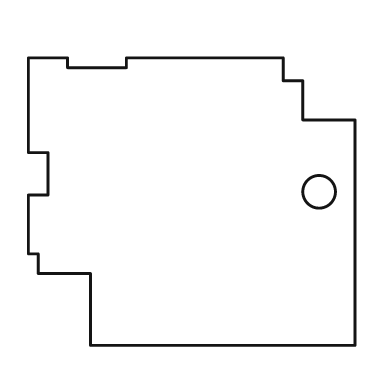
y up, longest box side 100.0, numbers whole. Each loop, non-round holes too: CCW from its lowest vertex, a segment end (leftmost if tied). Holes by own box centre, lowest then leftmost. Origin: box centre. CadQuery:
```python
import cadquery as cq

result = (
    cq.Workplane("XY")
    .moveTo(-31.0, -44.0)
    .lineTo(50.0, -44.0)
    .lineTo(50.0, 25.0)
    .lineTo(34.0, 25.0)
    .lineTo(34.0, 37.0)
    .lineTo(28.0, 37.0)
    .lineTo(28.0, 44.0)
    .lineTo(-20.0, 44.0)
    .lineTo(-20.0, 41.0)
    .lineTo(-38.0, 41.0)
    .lineTo(-38.0, 44.0)
    .lineTo(-50.0, 44.0)
    .lineTo(-50.0, 15.0)
    .lineTo(-44.0, 15.0)
    .lineTo(-44.0, 2.0)
    .lineTo(-50.0, 2.0)
    .lineTo(-50.0, -16.0)
    .lineTo(-47.0, -16.0)
    .lineTo(-47.0, -22.0)
    .lineTo(-31.0, -22.0)
    .close()
    .moveTo(39.0, 3.0)
    .circle(5.0)
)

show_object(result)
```